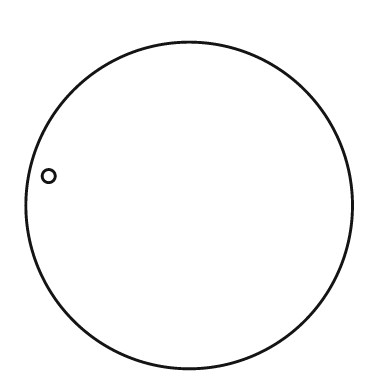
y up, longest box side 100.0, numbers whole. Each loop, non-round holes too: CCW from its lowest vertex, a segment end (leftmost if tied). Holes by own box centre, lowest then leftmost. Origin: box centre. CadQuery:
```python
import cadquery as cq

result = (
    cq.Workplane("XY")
    .moveTo(0.0, 0.0)
    .circle(50.0)
    .moveTo(-43.0, 9.0)
    .circle(2.0)
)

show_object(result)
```